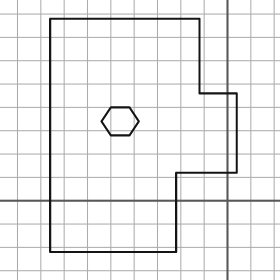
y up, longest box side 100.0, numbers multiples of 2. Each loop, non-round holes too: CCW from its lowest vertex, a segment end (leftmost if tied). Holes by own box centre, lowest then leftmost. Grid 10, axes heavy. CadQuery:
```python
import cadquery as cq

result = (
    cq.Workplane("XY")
    .moveTo(-76.0, -22.0)
    .lineTo(-22.0, -22.0)
    .lineTo(-22.0, 12.0)
    .lineTo(4.0, 12.0)
    .lineTo(4.0, 46.0)
    .lineTo(-12.0, 46.0)
    .lineTo(-12.0, 78.0)
    .lineTo(-76.0, 78.0)
    .close()
    .moveTo(-50.0, 28.0)
    .lineTo(-42.0, 28.0)
    .lineTo(-38.0, 34.0)
    .lineTo(-42.0, 40.0)
    .lineTo(-50.0, 40.0)
    .lineTo(-54.0, 34.0)
    .close()
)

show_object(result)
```